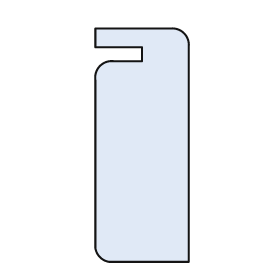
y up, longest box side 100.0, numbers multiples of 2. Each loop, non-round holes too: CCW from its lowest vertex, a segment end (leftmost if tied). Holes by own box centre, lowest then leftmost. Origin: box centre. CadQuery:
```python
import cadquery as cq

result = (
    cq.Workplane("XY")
    .moveTo(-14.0, -50.0)
    .lineTo(20.0, -50.0)
    .lineTo(20.0, 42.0)
    .threePointArc((18.0, 48.0), (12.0, 50.0))
    .lineTo(-20.0, 50.0)
    .lineTo(-20.0, 42.0)
    .lineTo(0.0, 42.0)
    .lineTo(0.0, 36.0)
    .lineTo(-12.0, 36.0)
    .threePointArc((-18.0, 34.0), (-20.0, 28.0))
    .lineTo(-20.0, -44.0)
    .threePointArc((-18.0, -48.0), (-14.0, -50.0))
    .close()
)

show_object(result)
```